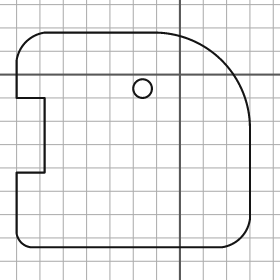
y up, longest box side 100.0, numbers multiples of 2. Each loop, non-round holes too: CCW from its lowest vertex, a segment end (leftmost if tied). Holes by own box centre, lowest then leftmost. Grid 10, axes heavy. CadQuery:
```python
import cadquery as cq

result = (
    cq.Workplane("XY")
    .moveTo(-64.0, -74.0)
    .lineTo(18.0, -74.0)
    .threePointArc((26.0, -70.0), (30.0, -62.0))
    .lineTo(30.0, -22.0)
    .threePointArc((18.0, 6.0), (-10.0, 18.0))
    .lineTo(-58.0, 18.0)
    .threePointArc((-66.0, 14.0), (-70.0, 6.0))
    .lineTo(-70.0, -10.0)
    .lineTo(-58.0, -10.0)
    .lineTo(-58.0, -42.0)
    .lineTo(-70.0, -42.0)
    .lineTo(-70.0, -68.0)
    .threePointArc((-68.0, -72.0), (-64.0, -74.0))
    .close()
    .moveTo(-16.0, -6.0)
    .circle(4.0)
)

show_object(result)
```